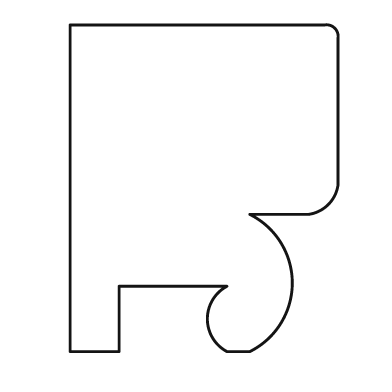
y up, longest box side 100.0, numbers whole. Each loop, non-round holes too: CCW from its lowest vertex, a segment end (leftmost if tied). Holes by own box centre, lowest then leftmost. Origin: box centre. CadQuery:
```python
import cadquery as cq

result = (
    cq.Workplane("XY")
    .moveTo(-41.0, -50.0)
    .lineTo(-26.0, -50.0)
    .lineTo(-26.0, -30.0)
    .lineTo(7.0, -30.0)
    .threePointArc((1.0, -40.0), (7.0, -50.0))
    .lineTo(14.0, -50.0)
    .threePointArc((27.0, -29.0), (14.0, -8.0))
    .lineTo(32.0, -8.0)
    .threePointArc((38.0, -5.0), (41.0, 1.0))
    .lineTo(41.0, 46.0)
    .threePointArc((40.0, 49.0), (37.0, 50.0))
    .lineTo(-41.0, 50.0)
    .close()
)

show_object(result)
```